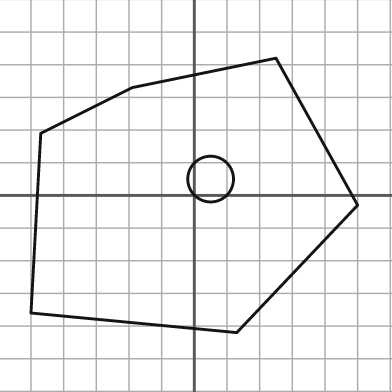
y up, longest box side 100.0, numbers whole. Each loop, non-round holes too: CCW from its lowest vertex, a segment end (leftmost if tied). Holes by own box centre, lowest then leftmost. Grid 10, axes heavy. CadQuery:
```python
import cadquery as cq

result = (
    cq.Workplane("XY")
    .moveTo(13.0, -42.0)
    .lineTo(50.0, -3.0)
    .lineTo(25.0, 42.0)
    .lineTo(-19.0, 33.0)
    .lineTo(-47.0, 19.0)
    .lineTo(-50.0, -36.0)
    .close()
    .moveTo(5.0, 5.0)
    .circle(7.0)
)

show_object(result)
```